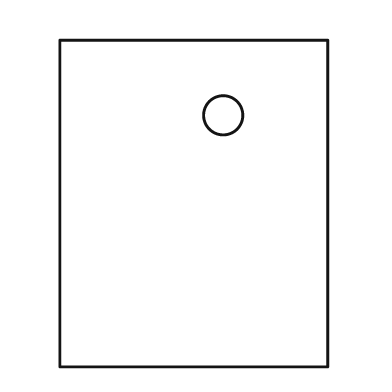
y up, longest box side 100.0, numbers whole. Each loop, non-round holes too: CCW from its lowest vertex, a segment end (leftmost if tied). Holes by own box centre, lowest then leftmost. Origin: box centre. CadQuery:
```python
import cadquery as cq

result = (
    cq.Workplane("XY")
    .moveTo(-41.0, -50.0)
    .lineTo(41.0, -50.0)
    .lineTo(41.0, 50.0)
    .lineTo(-41.0, 50.0)
    .close()
    .moveTo(9.0, 27.0)
    .circle(6.0)
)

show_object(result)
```